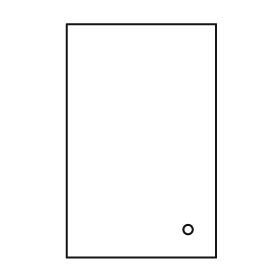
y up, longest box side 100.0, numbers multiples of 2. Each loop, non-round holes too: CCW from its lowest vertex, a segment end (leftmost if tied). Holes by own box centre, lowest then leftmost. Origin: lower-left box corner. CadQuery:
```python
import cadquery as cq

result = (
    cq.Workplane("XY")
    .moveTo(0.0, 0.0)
    .lineTo(64.0, 0.0)
    .lineTo(64.0, 100.0)
    .lineTo(0.0, 100.0)
    .close()
    .moveTo(52.0, 12.0)
    .circle(2.0)
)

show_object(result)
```